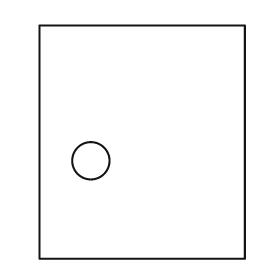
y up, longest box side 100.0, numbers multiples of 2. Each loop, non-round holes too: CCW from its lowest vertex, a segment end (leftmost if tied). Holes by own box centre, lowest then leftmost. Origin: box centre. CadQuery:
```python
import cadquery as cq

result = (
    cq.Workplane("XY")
    .moveTo(-44.0, -50.0)
    .lineTo(44.0, -50.0)
    .lineTo(44.0, 50.0)
    .lineTo(-44.0, 50.0)
    .close()
    .moveTo(-22.0, -8.0)
    .circle(8.0)
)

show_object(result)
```